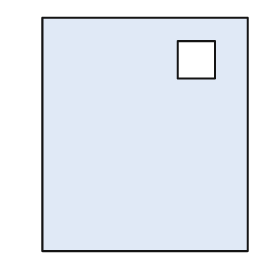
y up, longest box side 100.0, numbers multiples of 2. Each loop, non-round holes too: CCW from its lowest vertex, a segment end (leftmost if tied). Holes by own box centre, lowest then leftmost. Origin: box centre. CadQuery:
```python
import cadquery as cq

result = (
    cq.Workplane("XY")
    .moveTo(-44.0, -50.0)
    .lineTo(44.0, -50.0)
    .lineTo(44.0, 50.0)
    .lineTo(-44.0, 50.0)
    .close()
    .moveTo(14.0, 24.0)
    .lineTo(30.0, 24.0)
    .lineTo(30.0, 40.0)
    .lineTo(14.0, 40.0)
    .close()
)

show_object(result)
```